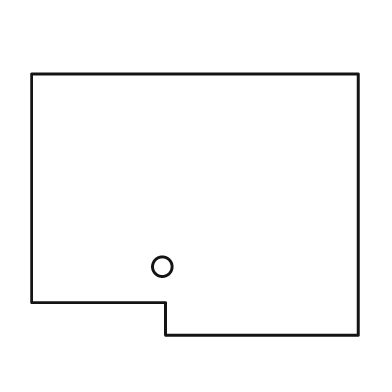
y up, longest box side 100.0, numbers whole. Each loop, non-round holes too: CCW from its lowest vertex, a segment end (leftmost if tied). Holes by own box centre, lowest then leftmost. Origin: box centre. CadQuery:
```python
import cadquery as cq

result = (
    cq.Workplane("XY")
    .moveTo(-9.0, -40.0)
    .lineTo(50.0, -40.0)
    .lineTo(50.0, 40.0)
    .lineTo(-50.0, 40.0)
    .lineTo(-50.0, -30.0)
    .lineTo(-9.0, -30.0)
    .close()
    .moveTo(-10.0, -19.0)
    .circle(3.0)
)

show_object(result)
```